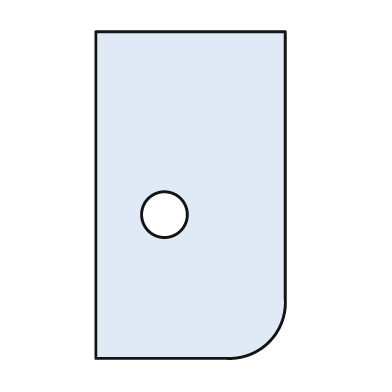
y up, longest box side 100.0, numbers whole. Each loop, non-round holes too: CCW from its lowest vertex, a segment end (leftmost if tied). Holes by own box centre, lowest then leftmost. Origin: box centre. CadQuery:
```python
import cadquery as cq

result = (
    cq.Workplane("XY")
    .moveTo(-29.0, -50.0)
    .lineTo(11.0, -50.0)
    .threePointArc((24.0, -45.0), (29.0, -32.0))
    .lineTo(29.0, 50.0)
    .lineTo(-29.0, 50.0)
    .close()
    .moveTo(-8.0, -6.0)
    .circle(7.0)
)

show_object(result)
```